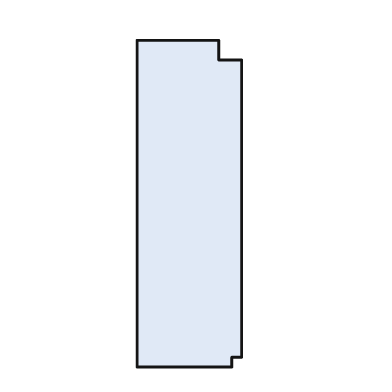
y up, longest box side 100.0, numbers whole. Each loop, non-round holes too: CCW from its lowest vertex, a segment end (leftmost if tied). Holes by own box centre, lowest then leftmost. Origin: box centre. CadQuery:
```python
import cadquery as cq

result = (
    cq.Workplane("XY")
    .moveTo(-16.0, -50.0)
    .lineTo(13.0, -50.0)
    .lineTo(13.0, -47.0)
    .lineTo(16.0, -47.0)
    .lineTo(16.0, 44.0)
    .lineTo(9.0, 44.0)
    .lineTo(9.0, 50.0)
    .lineTo(-16.0, 50.0)
    .close()
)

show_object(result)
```